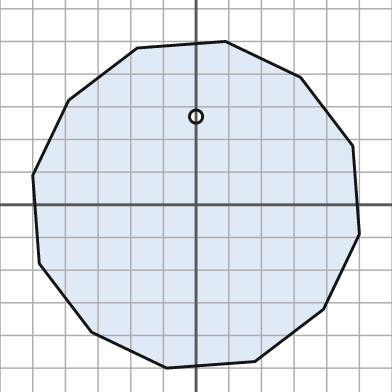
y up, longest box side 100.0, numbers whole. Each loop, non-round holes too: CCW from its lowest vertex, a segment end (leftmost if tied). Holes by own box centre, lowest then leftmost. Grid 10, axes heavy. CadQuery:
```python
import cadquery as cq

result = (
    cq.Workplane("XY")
    .moveTo(-9.0, -50.0)
    .lineTo(18.0, -48.0)
    .lineTo(39.0, -32.0)
    .lineTo(50.0, -9.0)
    .lineTo(48.0, 18.0)
    .lineTo(32.0, 39.0)
    .lineTo(9.0, 50.0)
    .lineTo(-18.0, 48.0)
    .lineTo(-39.0, 32.0)
    .lineTo(-50.0, 9.0)
    .lineTo(-48.0, -18.0)
    .lineTo(-32.0, -39.0)
    .close()
    .moveTo(0.0, 27.0)
    .circle(2.0)
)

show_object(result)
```